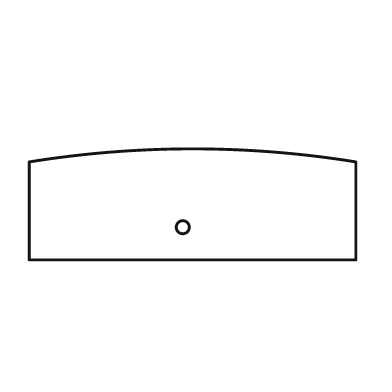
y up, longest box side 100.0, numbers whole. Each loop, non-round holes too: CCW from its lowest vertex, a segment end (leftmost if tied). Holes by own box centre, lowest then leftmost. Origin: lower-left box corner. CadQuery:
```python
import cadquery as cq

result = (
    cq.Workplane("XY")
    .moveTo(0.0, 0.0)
    .lineTo(100.0, 0.0)
    .lineTo(100.0, 30.0)
    .threePointArc((50.0, 34.0), (0.0, 30.0))
    .close()
    .moveTo(47.0, 10.0)
    .circle(2.0)
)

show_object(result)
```